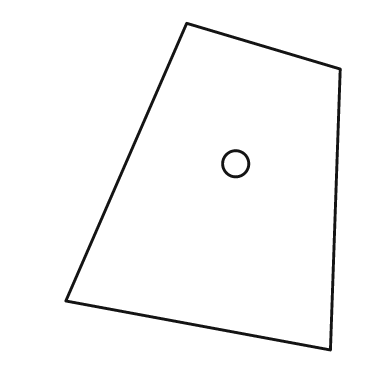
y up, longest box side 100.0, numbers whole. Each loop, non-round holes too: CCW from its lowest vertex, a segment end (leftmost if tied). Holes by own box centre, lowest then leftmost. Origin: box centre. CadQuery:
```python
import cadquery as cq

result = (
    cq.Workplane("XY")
    .moveTo(39.0, -50.0)
    .lineTo(42.0, 36.0)
    .lineTo(-5.0, 50.0)
    .lineTo(-42.0, -35.0)
    .close()
    .moveTo(10.0, 7.0)
    .circle(4.0)
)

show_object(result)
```